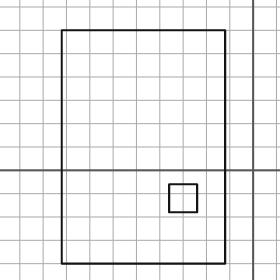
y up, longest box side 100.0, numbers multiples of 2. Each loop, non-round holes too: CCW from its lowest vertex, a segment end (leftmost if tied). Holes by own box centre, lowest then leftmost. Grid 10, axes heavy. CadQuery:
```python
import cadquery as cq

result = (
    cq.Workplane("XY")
    .moveTo(-82.0, -40.0)
    .lineTo(-12.0, -40.0)
    .lineTo(-12.0, 60.0)
    .lineTo(-82.0, 60.0)
    .close()
    .moveTo(-36.0, -18.0)
    .lineTo(-24.0, -18.0)
    .lineTo(-24.0, -6.0)
    .lineTo(-36.0, -6.0)
    .close()
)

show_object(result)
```